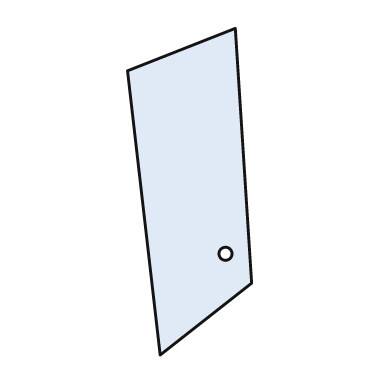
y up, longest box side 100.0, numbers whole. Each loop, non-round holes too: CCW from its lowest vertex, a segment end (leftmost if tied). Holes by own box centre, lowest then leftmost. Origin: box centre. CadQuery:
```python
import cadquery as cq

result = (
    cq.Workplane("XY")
    .moveTo(-9.0, -50.0)
    .lineTo(19.0, -28.0)
    .lineTo(14.0, 50.0)
    .lineTo(-19.0, 37.0)
    .close()
    .moveTo(11.0, -19.0)
    .circle(2.0)
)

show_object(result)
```